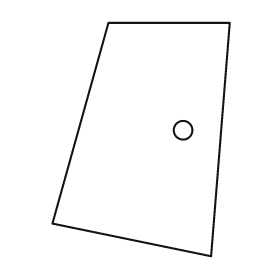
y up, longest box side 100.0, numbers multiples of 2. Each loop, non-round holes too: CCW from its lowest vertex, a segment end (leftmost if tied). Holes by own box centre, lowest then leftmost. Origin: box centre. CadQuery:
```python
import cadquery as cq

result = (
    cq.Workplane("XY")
    .moveTo(30.0, -50.0)
    .lineTo(38.0, 50.0)
    .lineTo(-14.0, 50.0)
    .lineTo(-38.0, -36.0)
    .close()
    .moveTo(18.0, 4.0)
    .circle(4.0)
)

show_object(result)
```